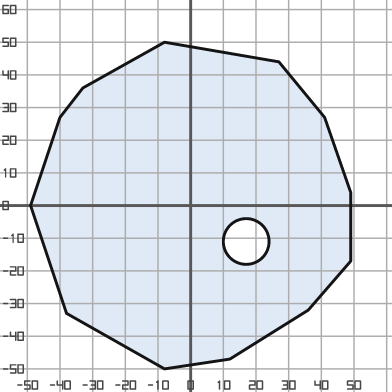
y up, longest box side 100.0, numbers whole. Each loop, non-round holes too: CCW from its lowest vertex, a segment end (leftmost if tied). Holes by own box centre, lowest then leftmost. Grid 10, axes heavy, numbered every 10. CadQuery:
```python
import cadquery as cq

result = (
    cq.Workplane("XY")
    .moveTo(-8.0, -50.0)
    .lineTo(12.0, -47.0)
    .lineTo(36.0, -32.0)
    .lineTo(49.0, -17.0)
    .lineTo(49.0, 4.0)
    .lineTo(41.0, 27.0)
    .lineTo(27.0, 44.0)
    .lineTo(-8.0, 50.0)
    .lineTo(-33.0, 36.0)
    .lineTo(-40.0, 27.0)
    .lineTo(-49.0, 0.0)
    .lineTo(-38.0, -33.0)
    .close()
    .moveTo(17.0, -11.0)
    .circle(7.0)
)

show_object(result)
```